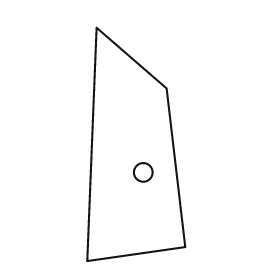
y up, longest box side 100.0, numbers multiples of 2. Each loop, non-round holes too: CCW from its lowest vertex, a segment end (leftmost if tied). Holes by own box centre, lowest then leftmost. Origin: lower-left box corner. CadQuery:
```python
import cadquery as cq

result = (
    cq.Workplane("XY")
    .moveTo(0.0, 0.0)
    .lineTo(42.0, 6.0)
    .lineTo(34.0, 74.0)
    .lineTo(4.0, 100.0)
    .close()
    .moveTo(24.0, 38.0)
    .circle(4.0)
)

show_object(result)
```